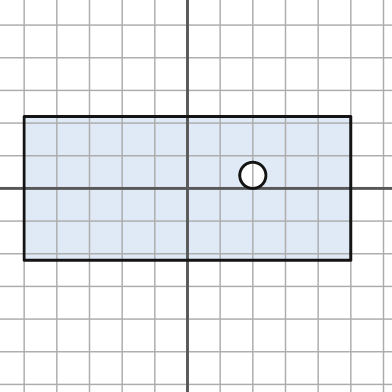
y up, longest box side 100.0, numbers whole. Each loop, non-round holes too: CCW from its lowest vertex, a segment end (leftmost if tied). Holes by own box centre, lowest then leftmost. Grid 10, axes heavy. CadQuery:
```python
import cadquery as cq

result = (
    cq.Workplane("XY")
    .moveTo(-50.0, -22.0)
    .lineTo(50.0, -22.0)
    .lineTo(50.0, 22.0)
    .lineTo(-50.0, 22.0)
    .close()
    .moveTo(20.0, 4.0)
    .circle(4.0)
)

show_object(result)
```